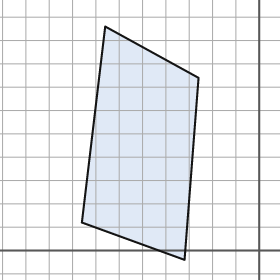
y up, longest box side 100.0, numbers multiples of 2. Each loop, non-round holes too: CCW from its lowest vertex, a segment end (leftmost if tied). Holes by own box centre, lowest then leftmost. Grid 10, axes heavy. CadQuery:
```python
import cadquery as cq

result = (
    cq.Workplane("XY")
    .moveTo(-32.0, -4.0)
    .lineTo(-26.0, 74.0)
    .lineTo(-66.0, 96.0)
    .lineTo(-76.0, 12.0)
    .close()
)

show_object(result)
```